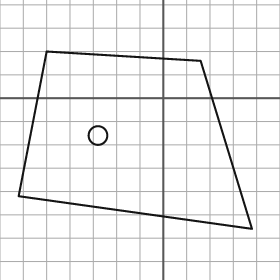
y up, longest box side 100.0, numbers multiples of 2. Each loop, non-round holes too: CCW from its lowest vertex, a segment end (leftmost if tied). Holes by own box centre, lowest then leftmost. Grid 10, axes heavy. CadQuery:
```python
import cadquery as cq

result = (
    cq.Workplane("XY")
    .moveTo(38.0, -56.0)
    .lineTo(16.0, 16.0)
    .lineTo(-50.0, 20.0)
    .lineTo(-62.0, -42.0)
    .close()
    .moveTo(-28.0, -16.0)
    .circle(4.0)
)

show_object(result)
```